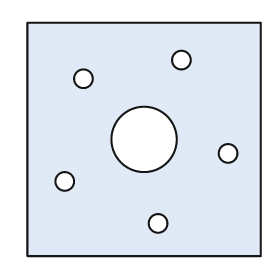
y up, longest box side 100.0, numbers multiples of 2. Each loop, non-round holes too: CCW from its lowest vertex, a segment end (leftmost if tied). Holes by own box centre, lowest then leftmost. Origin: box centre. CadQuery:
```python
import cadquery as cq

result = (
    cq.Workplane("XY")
    .moveTo(-50.0, -50.0)
    .lineTo(50.0, -50.0)
    .lineTo(50.0, 50.0)
    .lineTo(-50.0, 50.0)
    .close()
    .moveTo(6.0, -36.0)
    .circle(4.0)
    .moveTo(-34.0, -18.0)
    .circle(4.0)
    .moveTo(36.0, -6.0)
    .circle(4.0)
    .moveTo(0.0, 0.0)
    .circle(14.0)
    .moveTo(-26.0, 26.0)
    .circle(4.0)
    .moveTo(16.0, 34.0)
    .circle(4.0)
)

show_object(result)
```